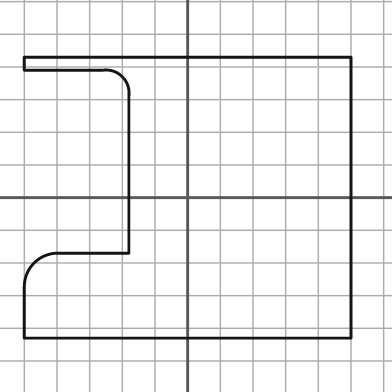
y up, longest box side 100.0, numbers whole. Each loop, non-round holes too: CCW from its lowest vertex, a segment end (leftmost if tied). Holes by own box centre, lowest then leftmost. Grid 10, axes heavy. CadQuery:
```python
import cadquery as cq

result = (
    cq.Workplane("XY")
    .moveTo(-50.0, -43.0)
    .lineTo(50.0, -43.0)
    .lineTo(50.0, 43.0)
    .lineTo(-50.0, 43.0)
    .lineTo(-50.0, 39.0)
    .lineTo(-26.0, 39.0)
    .threePointArc((-20.0, 37.0), (-18.0, 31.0))
    .lineTo(-18.0, -17.0)
    .lineTo(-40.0, -17.0)
    .threePointArc((-47.0, -20.0), (-50.0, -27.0))
    .close()
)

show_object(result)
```